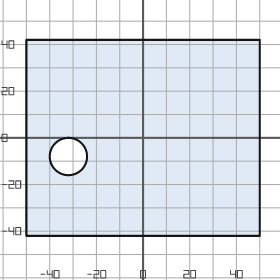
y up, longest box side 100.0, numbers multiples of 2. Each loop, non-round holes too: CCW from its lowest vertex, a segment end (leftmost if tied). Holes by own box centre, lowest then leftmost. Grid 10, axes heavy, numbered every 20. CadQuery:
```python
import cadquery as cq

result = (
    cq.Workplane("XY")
    .moveTo(-50.0, -42.0)
    .lineTo(50.0, -42.0)
    .lineTo(50.0, 42.0)
    .lineTo(-50.0, 42.0)
    .close()
    .moveTo(-32.0, -8.0)
    .circle(8.0)
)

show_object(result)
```